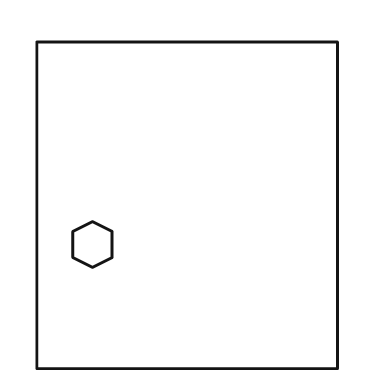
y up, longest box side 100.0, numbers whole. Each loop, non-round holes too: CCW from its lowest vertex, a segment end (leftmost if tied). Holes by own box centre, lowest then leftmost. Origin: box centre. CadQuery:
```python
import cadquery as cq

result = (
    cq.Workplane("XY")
    .moveTo(-46.0, -50.0)
    .lineTo(46.0, -50.0)
    .lineTo(46.0, 50.0)
    .lineTo(-46.0, 50.0)
    .close()
    .moveTo(-29.0, -19.0)
    .lineTo(-23.0, -16.0)
    .lineTo(-23.0, -8.0)
    .lineTo(-29.0, -5.0)
    .lineTo(-35.0, -8.0)
    .lineTo(-35.0, -16.0)
    .close()
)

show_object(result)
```